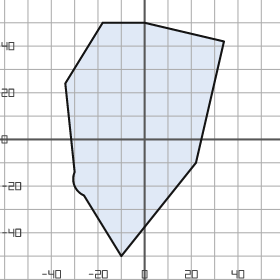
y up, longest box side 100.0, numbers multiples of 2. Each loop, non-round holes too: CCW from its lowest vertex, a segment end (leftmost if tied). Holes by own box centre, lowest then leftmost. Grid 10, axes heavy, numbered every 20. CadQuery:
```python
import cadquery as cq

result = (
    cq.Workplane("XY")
    .moveTo(-10.0, -50.0)
    .lineTo(22.0, -10.0)
    .lineTo(34.0, 42.0)
    .lineTo(0.0, 50.0)
    .lineTo(-18.0, 50.0)
    .lineTo(-34.0, 24.0)
    .lineTo(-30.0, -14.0)
    .threePointArc((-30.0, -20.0), (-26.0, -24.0))
    .close()
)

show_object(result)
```